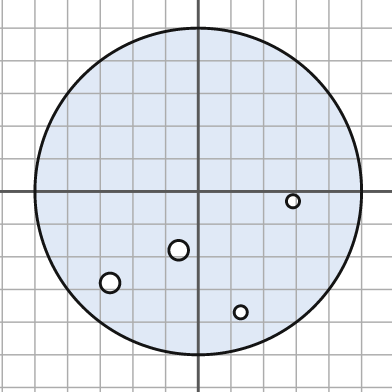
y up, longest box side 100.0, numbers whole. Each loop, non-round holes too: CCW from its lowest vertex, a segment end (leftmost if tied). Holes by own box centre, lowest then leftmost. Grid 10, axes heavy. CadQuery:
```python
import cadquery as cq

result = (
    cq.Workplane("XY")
    .moveTo(0.0, 0.0)
    .circle(50.0)
    .moveTo(13.0, -37.0)
    .circle(2.0)
    .moveTo(-27.0, -28.0)
    .circle(3.0)
    .moveTo(-6.0, -18.0)
    .circle(3.0)
    .moveTo(29.0, -3.0)
    .circle(2.0)
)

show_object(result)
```